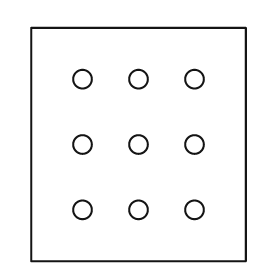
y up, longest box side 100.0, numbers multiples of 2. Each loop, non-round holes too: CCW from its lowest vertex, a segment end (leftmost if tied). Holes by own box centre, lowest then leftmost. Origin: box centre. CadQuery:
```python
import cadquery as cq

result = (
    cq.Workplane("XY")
    .moveTo(-46.0, -50.0)
    .lineTo(46.0, -50.0)
    .lineTo(46.0, 50.0)
    .lineTo(-46.0, 50.0)
    .close()
    .moveTo(-24.0, -28.0)
    .circle(4.0)
    .moveTo(0.0, -28.0)
    .circle(4.0)
    .moveTo(24.0, -28.0)
    .circle(4.0)
    .moveTo(-24.0, 0.0)
    .circle(4.0)
    .moveTo(0.0, 0.0)
    .circle(4.0)
    .moveTo(24.0, 0.0)
    .circle(4.0)
    .moveTo(-24.0, 28.0)
    .circle(4.0)
    .moveTo(0.0, 28.0)
    .circle(4.0)
    .moveTo(24.0, 28.0)
    .circle(4.0)
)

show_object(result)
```